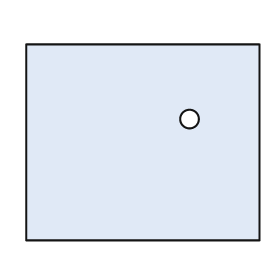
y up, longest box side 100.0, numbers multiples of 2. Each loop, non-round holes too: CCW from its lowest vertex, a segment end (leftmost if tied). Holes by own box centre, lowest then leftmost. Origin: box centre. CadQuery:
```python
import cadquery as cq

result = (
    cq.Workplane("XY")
    .moveTo(-50.0, -42.0)
    .lineTo(50.0, -42.0)
    .lineTo(50.0, 42.0)
    .lineTo(-50.0, 42.0)
    .close()
    .moveTo(20.0, 10.0)
    .circle(4.0)
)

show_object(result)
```